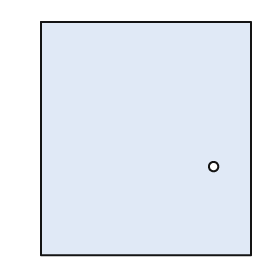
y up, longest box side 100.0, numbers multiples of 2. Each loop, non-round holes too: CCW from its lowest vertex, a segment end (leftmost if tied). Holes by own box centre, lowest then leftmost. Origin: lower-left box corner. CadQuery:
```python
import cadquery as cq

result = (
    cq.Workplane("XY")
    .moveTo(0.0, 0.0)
    .lineTo(90.0, 0.0)
    .lineTo(90.0, 100.0)
    .lineTo(0.0, 100.0)
    .close()
    .moveTo(74.0, 38.0)
    .circle(2.0)
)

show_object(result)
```